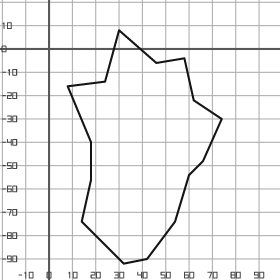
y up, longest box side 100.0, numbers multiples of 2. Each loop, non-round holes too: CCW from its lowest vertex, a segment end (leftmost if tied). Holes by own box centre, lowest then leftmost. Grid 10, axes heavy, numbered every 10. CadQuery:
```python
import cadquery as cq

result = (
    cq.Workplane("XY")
    .moveTo(32.0, -92.0)
    .lineTo(42.0, -90.0)
    .lineTo(54.0, -74.0)
    .lineTo(60.0, -54.0)
    .lineTo(66.0, -48.0)
    .lineTo(74.0, -30.0)
    .lineTo(62.0, -22.0)
    .lineTo(58.0, -4.0)
    .lineTo(46.0, -6.0)
    .lineTo(30.0, 8.0)
    .lineTo(24.0, -14.0)
    .lineTo(8.0, -16.0)
    .lineTo(18.0, -40.0)
    .lineTo(18.0, -56.0)
    .lineTo(14.0, -74.0)
    .close()
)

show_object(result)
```